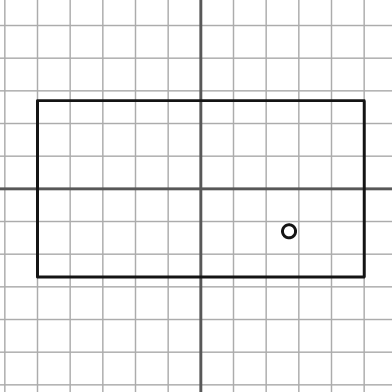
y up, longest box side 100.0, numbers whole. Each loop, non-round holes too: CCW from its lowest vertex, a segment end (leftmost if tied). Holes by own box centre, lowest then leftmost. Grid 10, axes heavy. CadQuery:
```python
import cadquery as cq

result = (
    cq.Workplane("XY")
    .moveTo(-50.0, -27.0)
    .lineTo(50.0, -27.0)
    .lineTo(50.0, 27.0)
    .lineTo(-50.0, 27.0)
    .close()
    .moveTo(27.0, -13.0)
    .circle(2.0)
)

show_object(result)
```